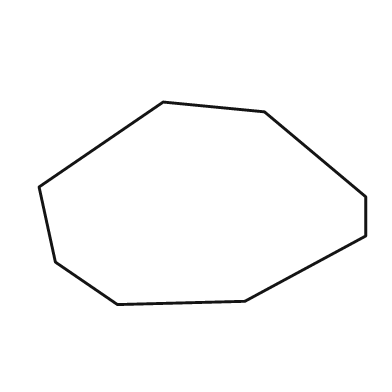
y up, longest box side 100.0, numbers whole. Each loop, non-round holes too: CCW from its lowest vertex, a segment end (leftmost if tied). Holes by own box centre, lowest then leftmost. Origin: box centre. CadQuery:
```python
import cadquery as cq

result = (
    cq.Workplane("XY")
    .moveTo(-26.0, -31.0)
    .lineTo(13.0, -30.0)
    .lineTo(50.0, -10.0)
    .lineTo(50.0, 2.0)
    .lineTo(19.0, 28.0)
    .lineTo(-12.0, 31.0)
    .lineTo(-50.0, 5.0)
    .lineTo(-45.0, -18.0)
    .close()
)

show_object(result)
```